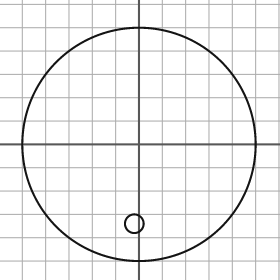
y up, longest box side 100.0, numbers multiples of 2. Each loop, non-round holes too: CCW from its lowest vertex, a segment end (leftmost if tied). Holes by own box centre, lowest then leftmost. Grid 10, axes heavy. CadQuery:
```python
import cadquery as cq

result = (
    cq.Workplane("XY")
    .moveTo(0.0, 0.0)
    .circle(50.0)
    .moveTo(-2.0, -34.0)
    .circle(4.0)
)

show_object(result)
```